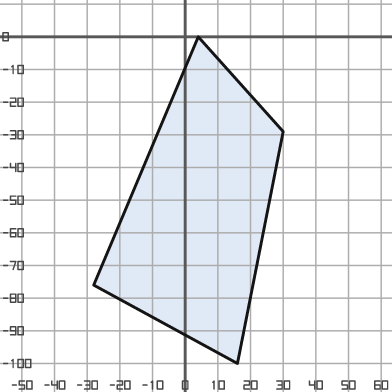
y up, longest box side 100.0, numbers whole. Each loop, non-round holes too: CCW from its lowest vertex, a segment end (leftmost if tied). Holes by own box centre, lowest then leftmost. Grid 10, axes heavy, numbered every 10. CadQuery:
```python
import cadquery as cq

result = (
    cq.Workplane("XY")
    .moveTo(16.0, -100.0)
    .lineTo(30.0, -29.0)
    .lineTo(4.0, 0.0)
    .lineTo(-28.0, -76.0)
    .close()
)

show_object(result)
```